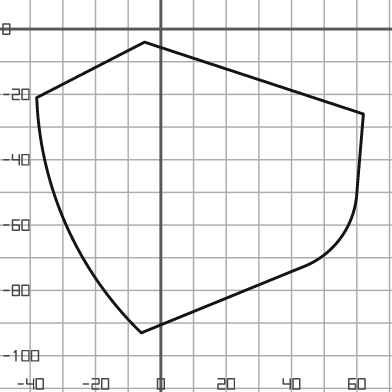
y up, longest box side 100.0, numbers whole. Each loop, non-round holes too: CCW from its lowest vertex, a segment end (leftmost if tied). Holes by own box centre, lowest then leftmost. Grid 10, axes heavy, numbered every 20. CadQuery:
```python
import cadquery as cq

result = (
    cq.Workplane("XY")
    .moveTo(-6.0, -93.0)
    .lineTo(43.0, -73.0)
    .threePointArc((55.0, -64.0), (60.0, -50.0))
    .lineTo(62.0, -26.0)
    .lineTo(-5.0, -4.0)
    .lineTo(-38.0, -21.0)
    .threePointArc((-29.0, -60.0), (-6.0, -93.0))
    .close()
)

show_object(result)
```